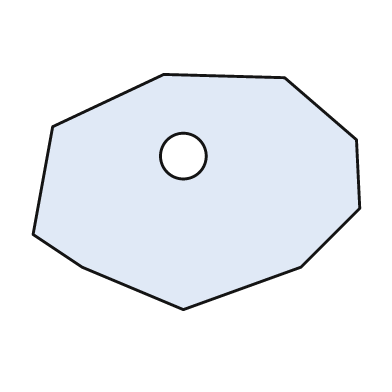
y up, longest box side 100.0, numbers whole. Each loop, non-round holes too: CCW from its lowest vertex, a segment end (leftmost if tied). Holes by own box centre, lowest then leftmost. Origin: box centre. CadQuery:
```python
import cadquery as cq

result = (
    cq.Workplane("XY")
    .moveTo(-4.0, -36.0)
    .lineTo(32.0, -23.0)
    .lineTo(50.0, -5.0)
    .lineTo(49.0, 16.0)
    .lineTo(27.0, 35.0)
    .lineTo(-10.0, 36.0)
    .lineTo(-44.0, 20.0)
    .lineTo(-50.0, -13.0)
    .lineTo(-35.0, -23.0)
    .close()
    .moveTo(-4.0, 11.0)
    .circle(7.0)
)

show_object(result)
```